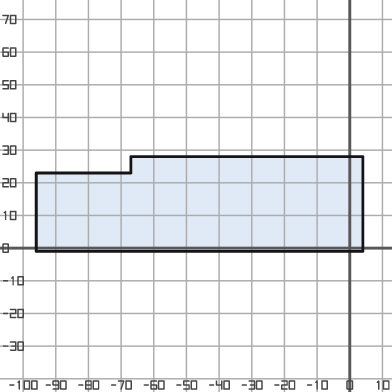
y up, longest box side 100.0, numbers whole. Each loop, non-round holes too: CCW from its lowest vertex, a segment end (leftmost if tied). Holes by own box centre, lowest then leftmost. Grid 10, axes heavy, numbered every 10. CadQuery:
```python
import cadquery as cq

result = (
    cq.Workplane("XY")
    .moveTo(-96.0, -1.0)
    .lineTo(4.0, -1.0)
    .lineTo(4.0, 28.0)
    .lineTo(-67.0, 28.0)
    .lineTo(-67.0, 23.0)
    .lineTo(-96.0, 23.0)
    .close()
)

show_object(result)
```